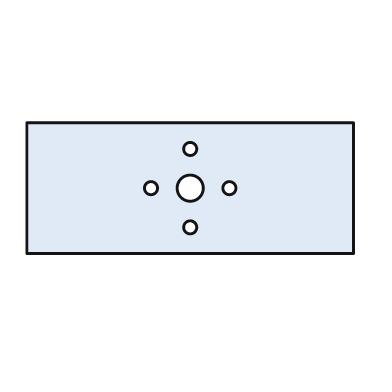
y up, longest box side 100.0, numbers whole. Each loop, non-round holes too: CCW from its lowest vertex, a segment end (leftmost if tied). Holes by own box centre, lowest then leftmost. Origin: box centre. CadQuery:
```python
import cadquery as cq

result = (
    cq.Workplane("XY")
    .moveTo(-50.0, -20.0)
    .lineTo(50.0, -20.0)
    .lineTo(50.0, 20.0)
    .lineTo(-50.0, 20.0)
    .close()
    .moveTo(0.0, -12.0)
    .circle(2.0)
    .moveTo(-12.0, 0.0)
    .circle(2.0)
    .moveTo(0.0, 0.0)
    .circle(4.0)
    .moveTo(12.0, 0.0)
    .circle(2.0)
    .moveTo(0.0, 12.0)
    .circle(2.0)
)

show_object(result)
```